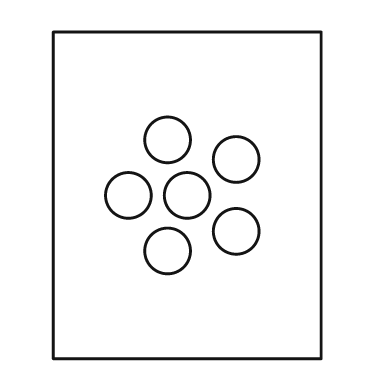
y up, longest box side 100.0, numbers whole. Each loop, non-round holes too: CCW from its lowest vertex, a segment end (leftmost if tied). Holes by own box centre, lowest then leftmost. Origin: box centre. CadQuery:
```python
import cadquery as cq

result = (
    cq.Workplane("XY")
    .moveTo(-41.0, -50.0)
    .lineTo(41.0, -50.0)
    .lineTo(41.0, 50.0)
    .lineTo(-41.0, 50.0)
    .close()
    .moveTo(-6.0, -17.0)
    .circle(7.0)
    .moveTo(15.0, -11.0)
    .circle(7.0)
    .moveTo(-18.0, 0.0)
    .circle(7.0)
    .moveTo(0.0, 0.0)
    .circle(7.0)
    .moveTo(15.0, 11.0)
    .circle(7.0)
    .moveTo(-6.0, 17.0)
    .circle(7.0)
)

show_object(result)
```